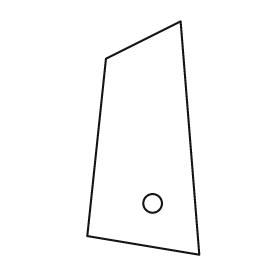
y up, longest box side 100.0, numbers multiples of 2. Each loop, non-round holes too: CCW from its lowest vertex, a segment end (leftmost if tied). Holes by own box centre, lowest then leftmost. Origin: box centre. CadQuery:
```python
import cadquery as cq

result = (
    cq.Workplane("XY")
    .moveTo(24.0, -50.0)
    .lineTo(16.0, 50.0)
    .lineTo(-16.0, 34.0)
    .lineTo(-24.0, -42.0)
    .close()
    .moveTo(4.0, -28.0)
    .circle(4.0)
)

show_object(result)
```